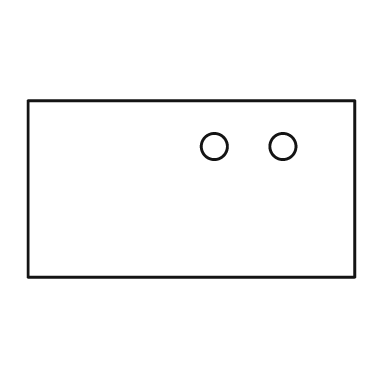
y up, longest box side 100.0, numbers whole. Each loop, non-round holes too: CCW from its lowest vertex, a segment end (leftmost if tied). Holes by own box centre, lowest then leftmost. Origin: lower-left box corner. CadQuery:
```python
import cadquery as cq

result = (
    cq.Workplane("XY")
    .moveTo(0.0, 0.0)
    .lineTo(100.0, 0.0)
    .lineTo(100.0, 54.0)
    .lineTo(0.0, 54.0)
    .close()
    .moveTo(57.0, 40.0)
    .circle(4.0)
    .moveTo(78.0, 40.0)
    .circle(4.0)
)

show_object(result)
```